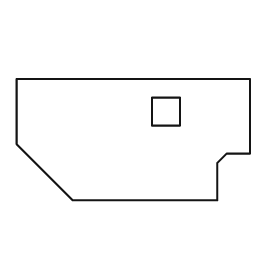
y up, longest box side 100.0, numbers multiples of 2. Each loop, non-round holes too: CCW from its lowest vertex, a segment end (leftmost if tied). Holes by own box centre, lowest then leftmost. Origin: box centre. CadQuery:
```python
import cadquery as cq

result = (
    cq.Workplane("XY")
    .moveTo(-26.0, -26.0)
    .lineTo(36.0, -26.0)
    .lineTo(36.0, -10.0)
    .lineTo(40.0, -6.0)
    .lineTo(50.0, -6.0)
    .lineTo(50.0, 26.0)
    .lineTo(-50.0, 26.0)
    .lineTo(-50.0, -2.0)
    .close()
    .moveTo(8.0, 6.0)
    .lineTo(20.0, 6.0)
    .lineTo(20.0, 18.0)
    .lineTo(8.0, 18.0)
    .close()
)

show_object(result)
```